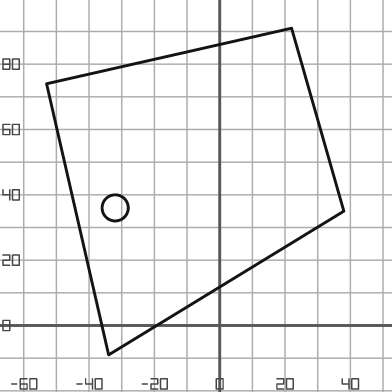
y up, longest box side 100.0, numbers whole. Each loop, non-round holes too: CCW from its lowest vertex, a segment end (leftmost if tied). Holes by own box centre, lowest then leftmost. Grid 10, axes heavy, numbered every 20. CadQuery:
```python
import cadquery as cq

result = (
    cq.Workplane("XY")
    .moveTo(-34.0, -9.0)
    .lineTo(38.0, 35.0)
    .lineTo(22.0, 91.0)
    .lineTo(-53.0, 74.0)
    .close()
    .moveTo(-32.0, 36.0)
    .circle(4.0)
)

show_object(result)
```